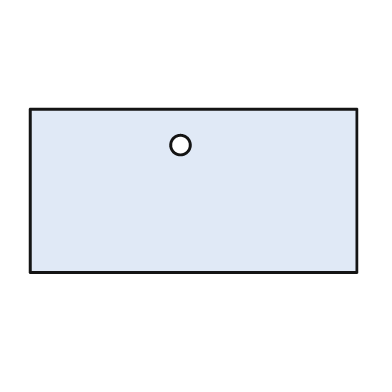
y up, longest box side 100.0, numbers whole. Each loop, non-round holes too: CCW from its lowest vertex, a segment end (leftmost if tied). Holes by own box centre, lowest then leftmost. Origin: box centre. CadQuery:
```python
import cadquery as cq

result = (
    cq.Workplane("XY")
    .moveTo(-50.0, -25.0)
    .lineTo(50.0, -25.0)
    .lineTo(50.0, 25.0)
    .lineTo(-50.0, 25.0)
    .close()
    .moveTo(-4.0, 14.0)
    .circle(3.0)
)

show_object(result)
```